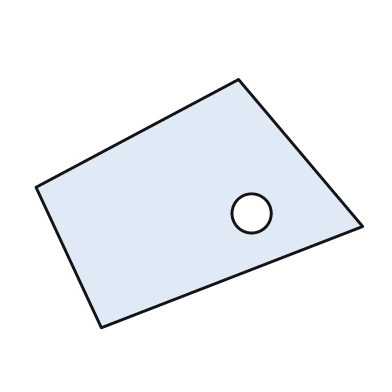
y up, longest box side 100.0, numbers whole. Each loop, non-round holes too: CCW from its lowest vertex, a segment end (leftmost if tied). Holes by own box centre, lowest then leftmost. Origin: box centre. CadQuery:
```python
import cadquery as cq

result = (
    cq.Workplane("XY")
    .moveTo(-30.0, -38.0)
    .lineTo(50.0, -7.0)
    .lineTo(12.0, 38.0)
    .lineTo(-50.0, 5.0)
    .close()
    .moveTo(16.0, -3.0)
    .circle(6.0)
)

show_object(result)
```